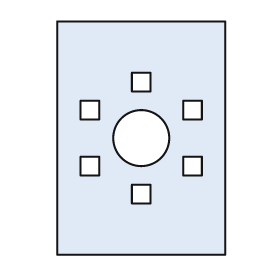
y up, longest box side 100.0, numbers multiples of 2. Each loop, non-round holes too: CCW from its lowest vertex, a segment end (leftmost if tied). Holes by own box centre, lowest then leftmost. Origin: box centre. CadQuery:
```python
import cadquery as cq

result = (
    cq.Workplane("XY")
    .moveTo(-36.0, -50.0)
    .lineTo(36.0, -50.0)
    .lineTo(36.0, 50.0)
    .lineTo(-36.0, 50.0)
    .close()
    .moveTo(-4.0, -28.0)
    .lineTo(4.0, -28.0)
    .lineTo(4.0, -20.0)
    .lineTo(-4.0, -20.0)
    .close()
    .moveTo(-26.0, -16.0)
    .lineTo(-18.0, -16.0)
    .lineTo(-18.0, -8.0)
    .lineTo(-26.0, -8.0)
    .close()
    .moveTo(18.0, -16.0)
    .lineTo(26.0, -16.0)
    .lineTo(26.0, -8.0)
    .lineTo(18.0, -8.0)
    .close()
    .moveTo(0.0, 0.0)
    .circle(12.0)
    .moveTo(-26.0, 8.0)
    .lineTo(-18.0, 8.0)
    .lineTo(-18.0, 16.0)
    .lineTo(-26.0, 16.0)
    .close()
    .moveTo(18.0, 8.0)
    .lineTo(26.0, 8.0)
    .lineTo(26.0, 16.0)
    .lineTo(18.0, 16.0)
    .close()
    .moveTo(-4.0, 20.0)
    .lineTo(4.0, 20.0)
    .lineTo(4.0, 28.0)
    .lineTo(-4.0, 28.0)
    .close()
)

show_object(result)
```